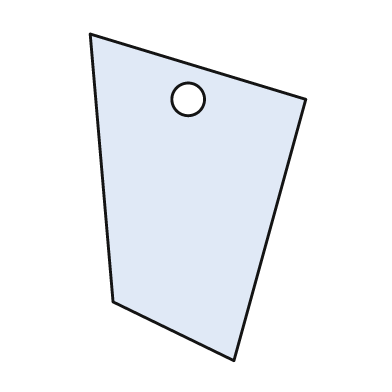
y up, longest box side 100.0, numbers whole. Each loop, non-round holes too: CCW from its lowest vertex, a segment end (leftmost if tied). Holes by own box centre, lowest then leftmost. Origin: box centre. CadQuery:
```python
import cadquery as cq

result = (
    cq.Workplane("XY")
    .moveTo(11.0, -50.0)
    .lineTo(33.0, 30.0)
    .lineTo(-33.0, 50.0)
    .lineTo(-26.0, -32.0)
    .close()
    .moveTo(-3.0, 30.0)
    .circle(5.0)
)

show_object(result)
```